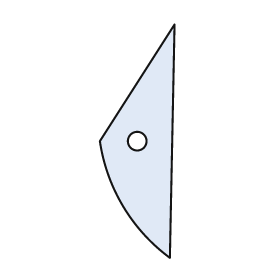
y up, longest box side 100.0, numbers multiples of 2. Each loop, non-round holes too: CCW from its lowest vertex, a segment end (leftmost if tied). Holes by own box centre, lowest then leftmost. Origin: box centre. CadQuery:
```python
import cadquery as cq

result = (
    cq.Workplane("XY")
    .moveTo(14.0, -50.0)
    .lineTo(16.0, 50.0)
    .lineTo(-16.0, 0.0)
    .threePointArc((-6.0, -28.0), (14.0, -50.0))
    .close()
    .moveTo(0.0, 0.0)
    .circle(4.0)
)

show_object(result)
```